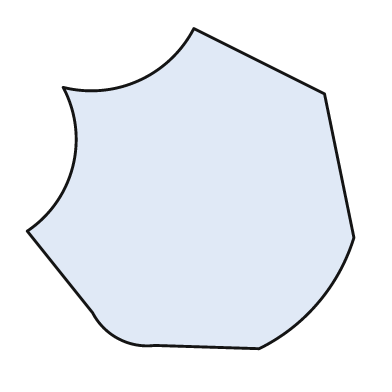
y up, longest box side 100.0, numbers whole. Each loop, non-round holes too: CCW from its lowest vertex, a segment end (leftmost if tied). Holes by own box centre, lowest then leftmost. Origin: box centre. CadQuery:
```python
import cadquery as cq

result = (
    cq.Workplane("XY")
    .moveTo(21.0, -49.0)
    .threePointArc((39.0, -35.0), (50.0, -15.0))
    .lineTo(41.0, 29.0)
    .lineTo(1.0, 49.0)
    .threePointArc((-16.0, 33.0), (-39.0, 31.0))
    .threePointArc((-36.0, 7.0), (-50.0, -13.0))
    .lineTo(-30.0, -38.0)
    .threePointArc((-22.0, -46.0), (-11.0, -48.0))
    .close()
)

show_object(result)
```